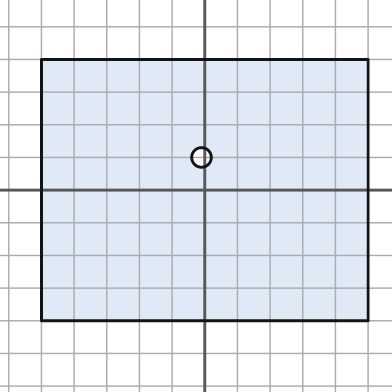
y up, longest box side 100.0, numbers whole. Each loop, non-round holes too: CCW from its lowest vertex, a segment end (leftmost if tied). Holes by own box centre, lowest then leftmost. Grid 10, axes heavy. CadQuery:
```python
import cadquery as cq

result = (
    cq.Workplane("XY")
    .moveTo(-50.0, -40.0)
    .lineTo(50.0, -40.0)
    .lineTo(50.0, 40.0)
    .lineTo(-50.0, 40.0)
    .close()
    .moveTo(-1.0, 10.0)
    .circle(3.0)
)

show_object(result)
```